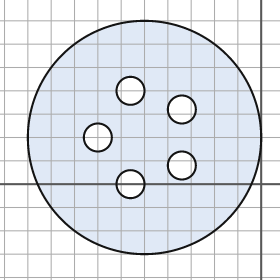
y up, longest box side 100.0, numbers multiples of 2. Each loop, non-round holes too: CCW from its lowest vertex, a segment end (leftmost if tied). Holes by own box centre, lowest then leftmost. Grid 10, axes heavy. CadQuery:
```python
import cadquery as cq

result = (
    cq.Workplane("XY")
    .moveTo(-50.0, 20.0)
    .circle(50.0)
    .moveTo(-56.0, 0.0)
    .circle(6.0)
    .moveTo(-34.0, 8.0)
    .circle(6.0)
    .moveTo(-70.0, 20.0)
    .circle(6.0)
    .moveTo(-34.0, 32.0)
    .circle(6.0)
    .moveTo(-56.0, 40.0)
    .circle(6.0)
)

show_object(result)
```